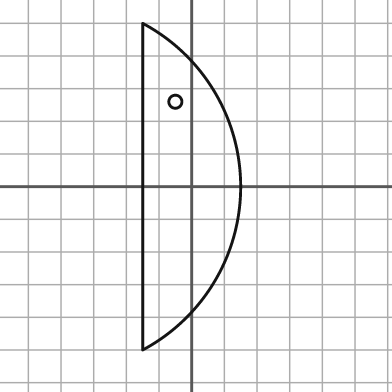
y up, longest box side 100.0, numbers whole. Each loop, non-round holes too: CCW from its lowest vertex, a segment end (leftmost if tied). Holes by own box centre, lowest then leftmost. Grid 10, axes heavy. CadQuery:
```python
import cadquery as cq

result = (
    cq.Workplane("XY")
    .moveTo(-15.0, -50.0)
    .threePointArc((15.0, 0.0), (-15.0, 50.0))
    .close()
    .moveTo(-5.0, 26.0)
    .circle(2.0)
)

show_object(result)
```